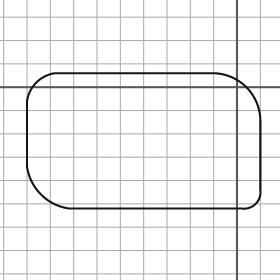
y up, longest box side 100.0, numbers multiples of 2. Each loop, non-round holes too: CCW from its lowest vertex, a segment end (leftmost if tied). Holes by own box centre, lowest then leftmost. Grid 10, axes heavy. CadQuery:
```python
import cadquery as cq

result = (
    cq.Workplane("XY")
    .moveTo(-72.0, -52.0)
    .lineTo(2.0, -52.0)
    .threePointArc((8.0, -50.0), (10.0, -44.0))
    .lineTo(10.0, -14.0)
    .threePointArc((4.0, 0.0), (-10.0, 6.0))
    .lineTo(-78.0, 6.0)
    .threePointArc((-86.0, 2.0), (-90.0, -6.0))
    .lineTo(-90.0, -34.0)
    .threePointArc((-84.0, -46.0), (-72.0, -52.0))
    .close()
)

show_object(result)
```